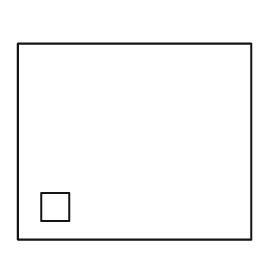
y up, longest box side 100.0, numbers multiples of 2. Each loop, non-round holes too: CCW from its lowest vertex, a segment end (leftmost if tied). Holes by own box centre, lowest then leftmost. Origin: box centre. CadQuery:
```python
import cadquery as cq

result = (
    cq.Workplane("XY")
    .moveTo(-50.0, -42.0)
    .lineTo(50.0, -42.0)
    .lineTo(50.0, 42.0)
    .lineTo(-50.0, 42.0)
    .close()
    .moveTo(-40.0, -34.0)
    .lineTo(-28.0, -34.0)
    .lineTo(-28.0, -22.0)
    .lineTo(-40.0, -22.0)
    .close()
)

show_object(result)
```